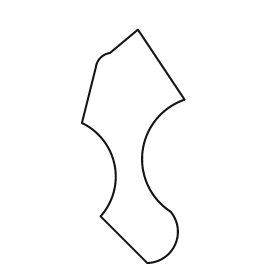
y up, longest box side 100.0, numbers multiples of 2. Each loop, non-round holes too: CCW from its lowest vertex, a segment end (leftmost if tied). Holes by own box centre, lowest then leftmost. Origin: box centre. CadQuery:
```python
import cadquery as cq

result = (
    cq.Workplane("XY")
    .moveTo(6.0, -50.0)
    .threePointArc((18.0, -42.0), (16.0, -28.0))
    .threePointArc((4.0, -2.0), (22.0, 20.0))
    .lineTo(2.0, 50.0)
    .lineTo(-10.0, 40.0)
    .threePointArc((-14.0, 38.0), (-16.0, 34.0))
    .lineTo(-22.0, 10.0)
    .threePointArc((-8.0, -8.0), (-14.0, -30.0))
    .close()
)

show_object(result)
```